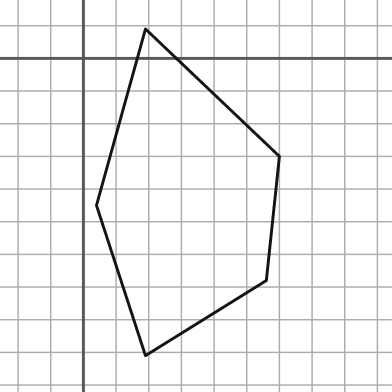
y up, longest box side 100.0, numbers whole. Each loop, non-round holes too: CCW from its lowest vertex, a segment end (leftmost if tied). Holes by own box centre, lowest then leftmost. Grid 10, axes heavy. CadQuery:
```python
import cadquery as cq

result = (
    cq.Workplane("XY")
    .moveTo(19.0, -91.0)
    .lineTo(56.0, -68.0)
    .lineTo(60.0, -30.0)
    .lineTo(19.0, 9.0)
    .lineTo(4.0, -45.0)
    .close()
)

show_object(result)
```